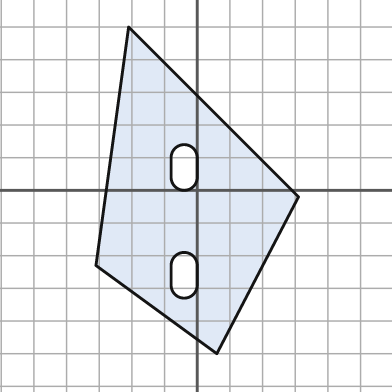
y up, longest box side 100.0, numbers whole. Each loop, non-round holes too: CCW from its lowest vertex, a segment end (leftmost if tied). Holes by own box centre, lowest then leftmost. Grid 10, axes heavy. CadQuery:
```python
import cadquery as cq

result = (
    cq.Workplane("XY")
    .moveTo(6.0, -50.0)
    .lineTo(31.0, -2.0)
    .lineTo(-21.0, 50.0)
    .lineTo(-31.0, -23.0)
    .close()
    .moveTo(-8.0, -29.0)
    .threePointArc((-4.0, -33.0), (0.0, -29.0))
    .lineTo(0.0, -23.0)
    .threePointArc((-4.0, -19.0), (-8.0, -23.0))
    .close()
    .moveTo(-8.0, 4.0)
    .threePointArc((-4.0, 0.0), (0.0, 4.0))
    .lineTo(0.0, 10.0)
    .threePointArc((-4.0, 14.0), (-8.0, 10.0))
    .close()
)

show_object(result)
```